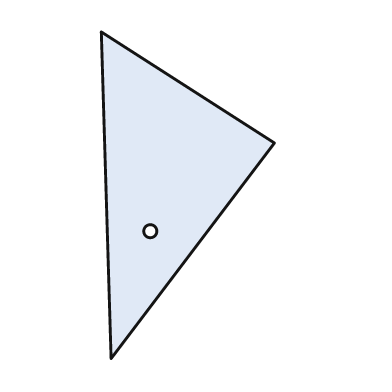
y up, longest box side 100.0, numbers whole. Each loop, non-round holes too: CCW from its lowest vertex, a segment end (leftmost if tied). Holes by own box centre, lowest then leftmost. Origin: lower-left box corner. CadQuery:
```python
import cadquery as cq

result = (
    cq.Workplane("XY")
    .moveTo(3.0, 0.0)
    .lineTo(53.0, 66.0)
    .lineTo(0.0, 100.0)
    .close()
    .moveTo(15.0, 39.0)
    .circle(2.0)
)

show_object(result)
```